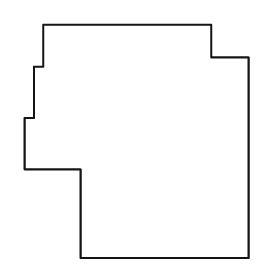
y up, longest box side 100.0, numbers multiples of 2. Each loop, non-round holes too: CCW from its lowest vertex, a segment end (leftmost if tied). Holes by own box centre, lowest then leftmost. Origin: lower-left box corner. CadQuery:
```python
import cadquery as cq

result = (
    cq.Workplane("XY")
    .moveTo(24.0, 0.0)
    .lineTo(96.0, 0.0)
    .lineTo(96.0, 86.0)
    .lineTo(80.0, 86.0)
    .lineTo(80.0, 100.0)
    .lineTo(8.0, 100.0)
    .lineTo(8.0, 82.0)
    .lineTo(4.0, 82.0)
    .lineTo(4.0, 60.0)
    .lineTo(0.0, 60.0)
    .lineTo(0.0, 38.0)
    .lineTo(24.0, 38.0)
    .close()
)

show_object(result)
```